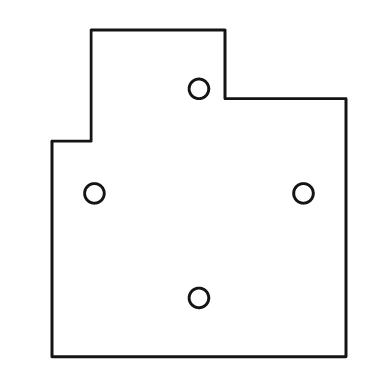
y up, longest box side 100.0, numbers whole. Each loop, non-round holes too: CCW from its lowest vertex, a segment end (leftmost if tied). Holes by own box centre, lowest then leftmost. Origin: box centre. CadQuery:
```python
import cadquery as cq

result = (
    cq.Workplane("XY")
    .moveTo(-45.0, -50.0)
    .lineTo(45.0, -50.0)
    .lineTo(45.0, 29.0)
    .lineTo(8.0, 29.0)
    .lineTo(8.0, 50.0)
    .lineTo(-33.0, 50.0)
    .lineTo(-33.0, 16.0)
    .lineTo(-45.0, 16.0)
    .close()
    .moveTo(0.0, -32.0)
    .circle(3.0)
    .moveTo(-32.0, 0.0)
    .circle(3.0)
    .moveTo(32.0, 0.0)
    .circle(3.0)
    .moveTo(0.0, 32.0)
    .circle(3.0)
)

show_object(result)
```